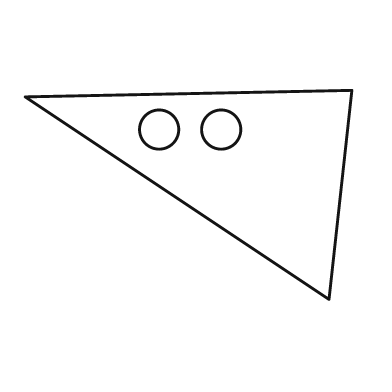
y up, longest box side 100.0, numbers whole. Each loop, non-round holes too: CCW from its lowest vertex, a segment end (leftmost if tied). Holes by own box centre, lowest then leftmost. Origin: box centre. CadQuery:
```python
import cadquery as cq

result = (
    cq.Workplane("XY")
    .moveTo(43.0, -32.0)
    .lineTo(50.0, 32.0)
    .lineTo(-50.0, 30.0)
    .close()
    .moveTo(-9.0, 20.0)
    .circle(6.0)
    .moveTo(10.0, 20.0)
    .circle(6.0)
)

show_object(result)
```